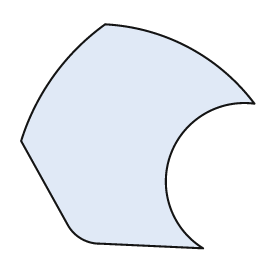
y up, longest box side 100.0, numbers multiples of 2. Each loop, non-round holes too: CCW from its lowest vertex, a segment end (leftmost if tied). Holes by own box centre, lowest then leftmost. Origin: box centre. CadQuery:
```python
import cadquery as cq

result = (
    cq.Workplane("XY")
    .moveTo(28.0, -48.0)
    .threePointArc((14.0, -8.0), (50.0, 14.0))
    .threePointArc((22.0, 38.0), (-14.0, 48.0))
    .threePointArc((-36.0, 26.0), (-50.0, -2.0))
    .lineTo(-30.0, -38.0)
    .threePointArc((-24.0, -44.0), (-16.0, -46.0))
    .close()
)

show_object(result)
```